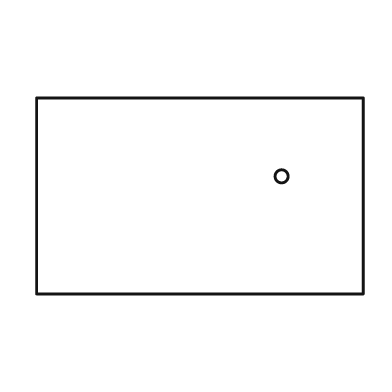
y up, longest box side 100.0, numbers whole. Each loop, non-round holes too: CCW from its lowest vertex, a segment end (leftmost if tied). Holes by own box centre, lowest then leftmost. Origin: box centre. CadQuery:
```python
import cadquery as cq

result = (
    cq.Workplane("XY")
    .moveTo(-50.0, -30.0)
    .lineTo(50.0, -30.0)
    .lineTo(50.0, 30.0)
    .lineTo(-50.0, 30.0)
    .close()
    .moveTo(25.0, 6.0)
    .circle(2.0)
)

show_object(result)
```